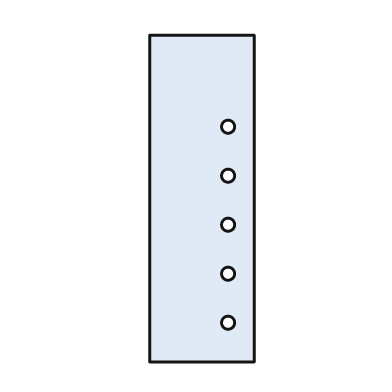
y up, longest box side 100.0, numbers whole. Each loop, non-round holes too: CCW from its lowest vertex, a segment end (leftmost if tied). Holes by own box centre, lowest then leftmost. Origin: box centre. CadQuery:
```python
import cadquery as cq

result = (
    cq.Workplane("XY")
    .moveTo(-16.0, -50.0)
    .lineTo(16.0, -50.0)
    .lineTo(16.0, 50.0)
    .lineTo(-16.0, 50.0)
    .close()
    .moveTo(8.0, -38.0)
    .circle(2.0)
    .moveTo(8.0, -23.0)
    .circle(2.0)
    .moveTo(8.0, -8.0)
    .circle(2.0)
    .moveTo(8.0, 7.0)
    .circle(2.0)
    .moveTo(8.0, 22.0)
    .circle(2.0)
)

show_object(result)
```